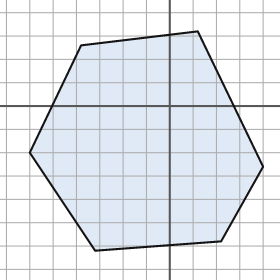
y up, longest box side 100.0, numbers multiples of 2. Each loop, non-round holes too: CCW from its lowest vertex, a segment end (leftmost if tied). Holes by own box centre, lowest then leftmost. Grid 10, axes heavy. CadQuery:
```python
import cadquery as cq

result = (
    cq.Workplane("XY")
    .moveTo(-32.0, -62.0)
    .lineTo(22.0, -58.0)
    .lineTo(40.0, -26.0)
    .lineTo(12.0, 32.0)
    .lineTo(-38.0, 26.0)
    .lineTo(-60.0, -20.0)
    .close()
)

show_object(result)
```